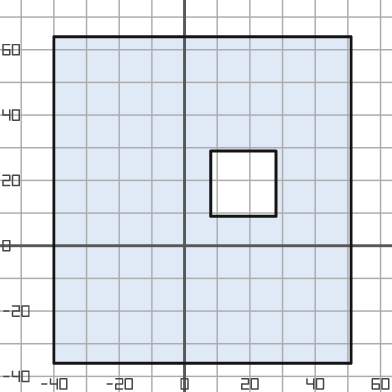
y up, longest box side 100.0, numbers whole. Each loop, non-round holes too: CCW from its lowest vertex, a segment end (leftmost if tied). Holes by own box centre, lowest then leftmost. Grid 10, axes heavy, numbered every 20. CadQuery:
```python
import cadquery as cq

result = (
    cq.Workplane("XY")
    .moveTo(-40.0, -36.0)
    .lineTo(51.0, -36.0)
    .lineTo(51.0, 64.0)
    .lineTo(-40.0, 64.0)
    .close()
    .moveTo(8.0, 9.0)
    .lineTo(28.0, 9.0)
    .lineTo(28.0, 29.0)
    .lineTo(8.0, 29.0)
    .close()
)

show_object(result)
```